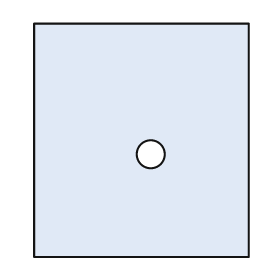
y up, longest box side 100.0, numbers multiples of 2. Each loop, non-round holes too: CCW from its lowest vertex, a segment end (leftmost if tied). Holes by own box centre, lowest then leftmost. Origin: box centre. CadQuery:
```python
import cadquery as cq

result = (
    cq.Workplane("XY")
    .moveTo(-46.0, -50.0)
    .lineTo(46.0, -50.0)
    .lineTo(46.0, 50.0)
    .lineTo(-46.0, 50.0)
    .close()
    .moveTo(4.0, -6.0)
    .circle(6.0)
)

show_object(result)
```